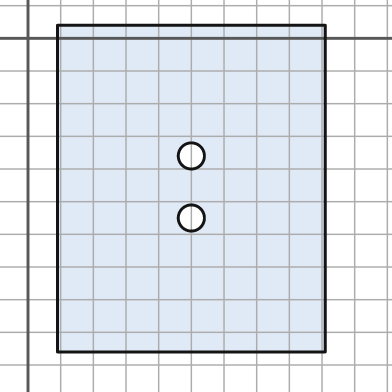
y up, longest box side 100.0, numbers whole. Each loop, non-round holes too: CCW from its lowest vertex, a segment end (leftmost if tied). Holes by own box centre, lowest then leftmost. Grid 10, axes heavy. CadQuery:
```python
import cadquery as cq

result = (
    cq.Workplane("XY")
    .moveTo(9.0, -96.0)
    .lineTo(91.0, -96.0)
    .lineTo(91.0, 4.0)
    .lineTo(9.0, 4.0)
    .close()
    .moveTo(50.0, -55.0)
    .circle(4.0)
    .moveTo(50.0, -36.0)
    .circle(4.0)
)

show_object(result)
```